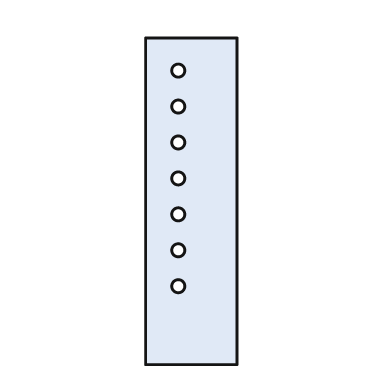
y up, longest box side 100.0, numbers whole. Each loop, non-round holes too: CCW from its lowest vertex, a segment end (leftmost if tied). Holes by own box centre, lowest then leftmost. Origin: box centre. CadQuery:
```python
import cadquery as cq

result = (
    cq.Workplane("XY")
    .moveTo(-14.0, -50.0)
    .lineTo(14.0, -50.0)
    .lineTo(14.0, 50.0)
    .lineTo(-14.0, 50.0)
    .close()
    .moveTo(-4.0, -26.0)
    .circle(2.0)
    .moveTo(-4.0, -15.0)
    .circle(2.0)
    .moveTo(-4.0, -4.0)
    .circle(2.0)
    .moveTo(-4.0, 7.0)
    .circle(2.0)
    .moveTo(-4.0, 18.0)
    .circle(2.0)
    .moveTo(-4.0, 29.0)
    .circle(2.0)
    .moveTo(-4.0, 40.0)
    .circle(2.0)
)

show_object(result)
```